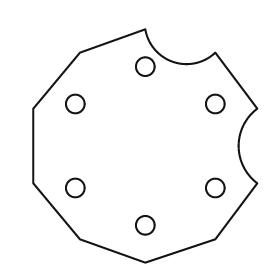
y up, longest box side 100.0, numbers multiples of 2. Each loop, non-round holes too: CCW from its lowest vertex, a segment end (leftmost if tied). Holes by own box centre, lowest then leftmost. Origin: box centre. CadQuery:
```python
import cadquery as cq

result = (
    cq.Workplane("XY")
    .moveTo(0.0, -50.0)
    .lineTo(30.0, -40.0)
    .lineTo(48.0, -16.0)
    .threePointArc((40.0, 0.0), (48.0, 16.0))
    .lineTo(30.0, 40.0)
    .threePointArc((12.0, 36.0), (0.0, 50.0))
    .lineTo(-28.0, 40.0)
    .lineTo(-48.0, 16.0)
    .lineTo(-48.0, -16.0)
    .lineTo(-28.0, -40.0)
    .close()
    .moveTo(0.0, -34.0)
    .circle(4.0)
    .moveTo(-30.0, -18.0)
    .circle(4.0)
    .moveTo(30.0, -18.0)
    .circle(4.0)
    .moveTo(-30.0, 18.0)
    .circle(4.0)
    .moveTo(30.0, 18.0)
    .circle(4.0)
    .moveTo(0.0, 34.0)
    .circle(4.0)
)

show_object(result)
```